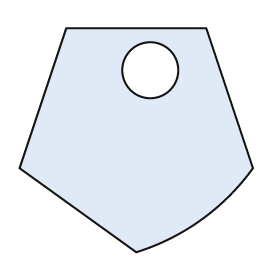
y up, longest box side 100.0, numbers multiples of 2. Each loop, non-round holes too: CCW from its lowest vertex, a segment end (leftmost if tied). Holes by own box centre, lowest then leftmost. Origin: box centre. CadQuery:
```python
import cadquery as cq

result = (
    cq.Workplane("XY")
    .moveTo(0.0, -48.0)
    .threePointArc((28.0, -34.0), (50.0, -12.0))
    .lineTo(30.0, 48.0)
    .lineTo(-30.0, 48.0)
    .lineTo(-50.0, -12.0)
    .close()
    .moveTo(6.0, 30.0)
    .circle(12.0)
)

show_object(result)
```